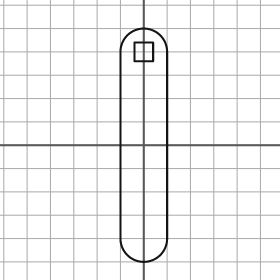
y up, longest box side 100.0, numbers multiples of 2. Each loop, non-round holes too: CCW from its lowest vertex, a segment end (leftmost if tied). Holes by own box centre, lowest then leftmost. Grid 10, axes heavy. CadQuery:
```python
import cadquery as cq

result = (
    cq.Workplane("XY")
    .moveTo(-10.0, -40.0)
    .threePointArc((0.0, -50.0), (10.0, -40.0))
    .lineTo(10.0, 40.0)
    .threePointArc((0.0, 50.0), (-10.0, 40.0))
    .close()
    .moveTo(-4.0, 36.0)
    .lineTo(4.0, 36.0)
    .lineTo(4.0, 44.0)
    .lineTo(-4.0, 44.0)
    .close()
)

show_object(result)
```